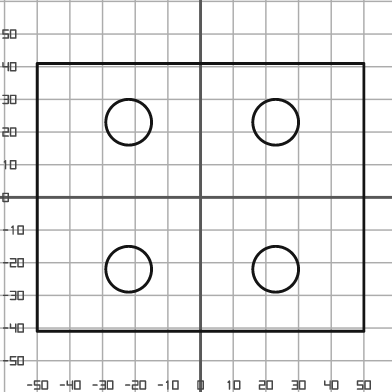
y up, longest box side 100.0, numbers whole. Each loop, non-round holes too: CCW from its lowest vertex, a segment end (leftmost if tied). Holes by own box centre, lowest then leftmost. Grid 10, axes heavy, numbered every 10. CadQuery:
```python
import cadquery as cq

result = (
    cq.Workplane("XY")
    .moveTo(-50.0, -41.0)
    .lineTo(50.0, -41.0)
    .lineTo(50.0, 41.0)
    .lineTo(-50.0, 41.0)
    .close()
    .moveTo(-22.0, -22.0)
    .circle(7.0)
    .moveTo(23.0, -22.0)
    .circle(7.0)
    .moveTo(-22.0, 23.0)
    .circle(7.0)
    .moveTo(23.0, 23.0)
    .circle(7.0)
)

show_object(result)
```